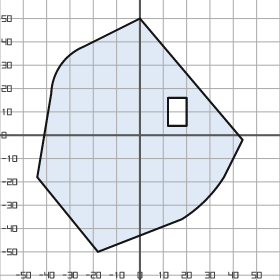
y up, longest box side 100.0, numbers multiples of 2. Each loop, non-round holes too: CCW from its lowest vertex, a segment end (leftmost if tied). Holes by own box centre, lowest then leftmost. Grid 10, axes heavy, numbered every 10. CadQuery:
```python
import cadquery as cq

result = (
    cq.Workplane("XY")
    .moveTo(-18.0, -50.0)
    .lineTo(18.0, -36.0)
    .threePointArc((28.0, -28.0), (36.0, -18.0))
    .lineTo(44.0, -2.0)
    .lineTo(0.0, 50.0)
    .lineTo(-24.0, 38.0)
    .threePointArc((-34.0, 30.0), (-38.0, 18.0))
    .lineTo(-44.0, -18.0)
    .close()
    .moveTo(12.0, 4.0)
    .lineTo(20.0, 4.0)
    .lineTo(20.0, 16.0)
    .lineTo(12.0, 16.0)
    .close()
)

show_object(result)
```